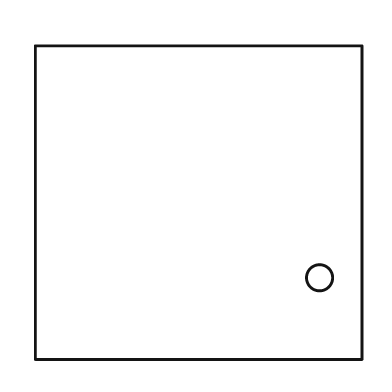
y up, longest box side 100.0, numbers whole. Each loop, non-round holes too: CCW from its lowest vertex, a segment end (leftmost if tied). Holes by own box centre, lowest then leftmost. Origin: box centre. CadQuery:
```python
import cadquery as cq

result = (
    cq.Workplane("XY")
    .moveTo(-50.0, -48.0)
    .lineTo(50.0, -48.0)
    .lineTo(50.0, 48.0)
    .lineTo(-50.0, 48.0)
    .close()
    .moveTo(37.0, -23.0)
    .circle(4.0)
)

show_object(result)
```